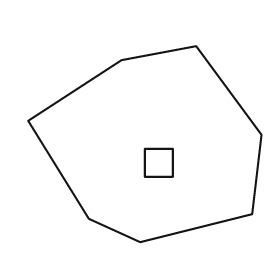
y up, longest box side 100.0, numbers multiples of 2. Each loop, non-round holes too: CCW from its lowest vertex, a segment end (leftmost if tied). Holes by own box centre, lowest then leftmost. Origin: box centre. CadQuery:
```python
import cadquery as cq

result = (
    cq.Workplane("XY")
    .moveTo(-2.0, -42.0)
    .lineTo(46.0, -30.0)
    .lineTo(50.0, 4.0)
    .lineTo(22.0, 42.0)
    .lineTo(-10.0, 36.0)
    .lineTo(-50.0, 10.0)
    .lineTo(-24.0, -32.0)
    .close()
    .moveTo(0.0, -14.0)
    .lineTo(12.0, -14.0)
    .lineTo(12.0, -2.0)
    .lineTo(0.0, -2.0)
    .close()
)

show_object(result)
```